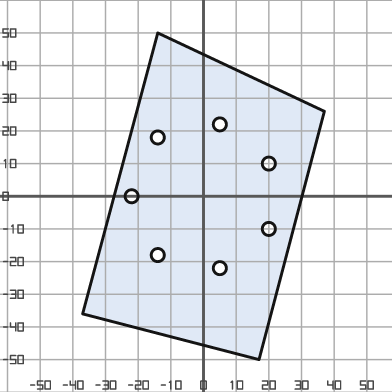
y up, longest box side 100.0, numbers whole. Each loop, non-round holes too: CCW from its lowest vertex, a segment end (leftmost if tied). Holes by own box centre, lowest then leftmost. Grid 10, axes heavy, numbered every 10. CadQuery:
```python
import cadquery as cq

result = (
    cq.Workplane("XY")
    .moveTo(17.0, -50.0)
    .lineTo(37.0, 26.0)
    .lineTo(-14.0, 50.0)
    .lineTo(-37.0, -36.0)
    .close()
    .moveTo(5.0, -22.0)
    .circle(2.0)
    .moveTo(-14.0, -18.0)
    .circle(2.0)
    .moveTo(20.0, -10.0)
    .circle(2.0)
    .moveTo(-22.0, 0.0)
    .circle(2.0)
    .moveTo(20.0, 10.0)
    .circle(2.0)
    .moveTo(-14.0, 18.0)
    .circle(2.0)
    .moveTo(5.0, 22.0)
    .circle(2.0)
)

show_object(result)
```